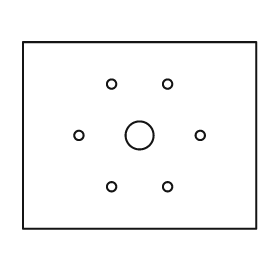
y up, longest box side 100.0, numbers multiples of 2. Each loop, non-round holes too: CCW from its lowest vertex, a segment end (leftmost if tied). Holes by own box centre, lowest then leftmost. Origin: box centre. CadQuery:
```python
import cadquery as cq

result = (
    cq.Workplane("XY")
    .moveTo(-50.0, -40.0)
    .lineTo(50.0, -40.0)
    .lineTo(50.0, 40.0)
    .lineTo(-50.0, 40.0)
    .close()
    .moveTo(-12.0, -22.0)
    .circle(2.0)
    .moveTo(12.0, -22.0)
    .circle(2.0)
    .moveTo(-26.0, 0.0)
    .circle(2.0)
    .moveTo(0.0, 0.0)
    .circle(6.0)
    .moveTo(26.0, 0.0)
    .circle(2.0)
    .moveTo(-12.0, 22.0)
    .circle(2.0)
    .moveTo(12.0, 22.0)
    .circle(2.0)
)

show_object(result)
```